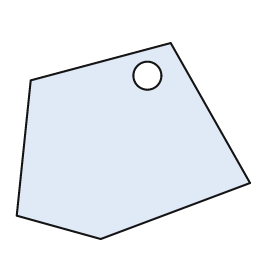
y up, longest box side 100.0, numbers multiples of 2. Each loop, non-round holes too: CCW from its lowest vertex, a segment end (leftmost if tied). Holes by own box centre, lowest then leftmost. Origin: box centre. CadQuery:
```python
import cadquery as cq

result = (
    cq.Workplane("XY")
    .moveTo(-14.0, -42.0)
    .lineTo(50.0, -18.0)
    .lineTo(16.0, 42.0)
    .lineTo(-44.0, 26.0)
    .lineTo(-50.0, -32.0)
    .close()
    .moveTo(6.0, 28.0)
    .circle(6.0)
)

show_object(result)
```